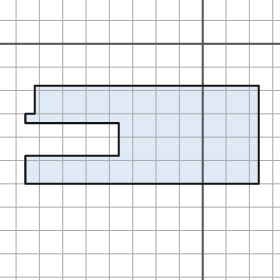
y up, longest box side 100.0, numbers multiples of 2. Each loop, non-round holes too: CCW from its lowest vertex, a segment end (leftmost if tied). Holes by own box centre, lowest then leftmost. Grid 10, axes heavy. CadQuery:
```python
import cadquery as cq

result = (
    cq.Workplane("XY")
    .moveTo(-76.0, -60.0)
    .lineTo(24.0, -60.0)
    .lineTo(24.0, -18.0)
    .lineTo(-72.0, -18.0)
    .lineTo(-72.0, -30.0)
    .lineTo(-76.0, -30.0)
    .lineTo(-76.0, -34.0)
    .lineTo(-36.0, -34.0)
    .lineTo(-36.0, -48.0)
    .lineTo(-76.0, -48.0)
    .close()
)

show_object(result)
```